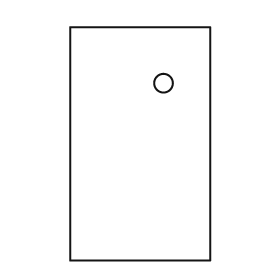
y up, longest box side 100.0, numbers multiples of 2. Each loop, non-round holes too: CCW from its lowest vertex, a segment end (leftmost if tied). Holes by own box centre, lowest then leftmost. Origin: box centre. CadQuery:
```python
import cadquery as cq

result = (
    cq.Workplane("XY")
    .moveTo(-30.0, -50.0)
    .lineTo(30.0, -50.0)
    .lineTo(30.0, 50.0)
    .lineTo(-30.0, 50.0)
    .close()
    .moveTo(10.0, 26.0)
    .circle(4.0)
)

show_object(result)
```